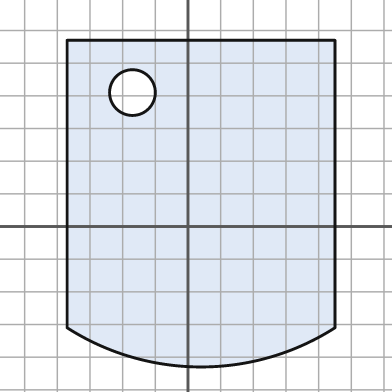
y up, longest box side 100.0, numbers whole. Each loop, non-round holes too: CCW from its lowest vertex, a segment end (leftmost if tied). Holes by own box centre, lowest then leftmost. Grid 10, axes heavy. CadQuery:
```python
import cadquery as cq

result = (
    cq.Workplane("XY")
    .moveTo(-37.0, -31.0)
    .threePointArc((4.0, -43.0), (45.0, -31.0))
    .lineTo(45.0, 57.0)
    .lineTo(-37.0, 57.0)
    .close()
    .moveTo(-17.0, 41.0)
    .circle(7.0)
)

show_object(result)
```